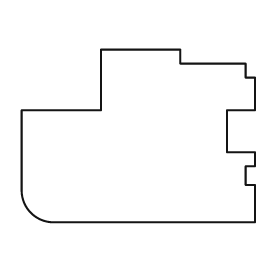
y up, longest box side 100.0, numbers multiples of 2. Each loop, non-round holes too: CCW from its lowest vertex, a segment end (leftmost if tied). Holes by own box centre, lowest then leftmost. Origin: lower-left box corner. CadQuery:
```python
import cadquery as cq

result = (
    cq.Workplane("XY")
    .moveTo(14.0, 0.0)
    .lineTo(100.0, 0.0)
    .lineTo(100.0, 16.0)
    .lineTo(96.0, 16.0)
    .lineTo(96.0, 24.0)
    .lineTo(100.0, 24.0)
    .lineTo(100.0, 30.0)
    .lineTo(88.0, 30.0)
    .lineTo(88.0, 48.0)
    .lineTo(100.0, 48.0)
    .lineTo(100.0, 62.0)
    .lineTo(96.0, 62.0)
    .lineTo(96.0, 68.0)
    .lineTo(68.0, 68.0)
    .lineTo(68.0, 74.0)
    .lineTo(34.0, 74.0)
    .lineTo(34.0, 48.0)
    .lineTo(0.0, 48.0)
    .lineTo(0.0, 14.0)
    .threePointArc((4.0, 4.0), (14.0, 0.0))
    .close()
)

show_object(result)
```